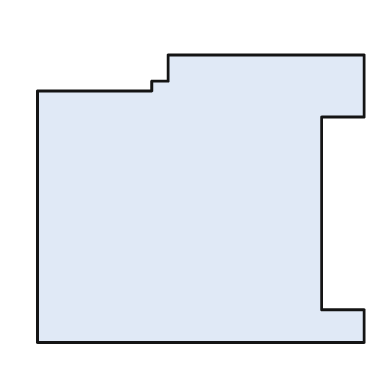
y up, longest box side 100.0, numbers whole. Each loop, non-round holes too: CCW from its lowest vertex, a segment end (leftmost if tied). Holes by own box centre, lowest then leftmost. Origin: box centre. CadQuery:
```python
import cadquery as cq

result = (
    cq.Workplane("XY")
    .moveTo(-50.0, -44.0)
    .lineTo(50.0, -44.0)
    .lineTo(50.0, -34.0)
    .lineTo(37.0, -34.0)
    .lineTo(37.0, 25.0)
    .lineTo(50.0, 25.0)
    .lineTo(50.0, 44.0)
    .lineTo(-10.0, 44.0)
    .lineTo(-10.0, 36.0)
    .lineTo(-15.0, 36.0)
    .lineTo(-15.0, 33.0)
    .lineTo(-50.0, 33.0)
    .close()
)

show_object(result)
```